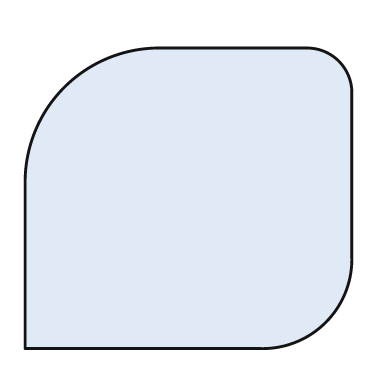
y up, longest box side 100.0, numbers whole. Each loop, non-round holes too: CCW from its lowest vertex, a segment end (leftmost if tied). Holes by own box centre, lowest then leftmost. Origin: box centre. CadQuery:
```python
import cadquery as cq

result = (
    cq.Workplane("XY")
    .moveTo(-50.0, -46.0)
    .lineTo(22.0, -46.0)
    .threePointArc((42.0, -38.0), (50.0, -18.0))
    .lineTo(50.0, 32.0)
    .threePointArc((46.0, 42.0), (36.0, 46.0))
    .lineTo(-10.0, 46.0)
    .threePointArc((-38.0, 34.0), (-50.0, 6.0))
    .close()
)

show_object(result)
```